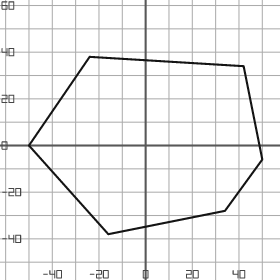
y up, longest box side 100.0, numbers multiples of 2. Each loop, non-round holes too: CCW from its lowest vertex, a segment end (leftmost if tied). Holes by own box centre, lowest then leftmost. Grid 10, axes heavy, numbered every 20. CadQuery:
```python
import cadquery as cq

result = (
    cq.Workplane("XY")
    .moveTo(-16.0, -38.0)
    .lineTo(34.0, -28.0)
    .lineTo(50.0, -6.0)
    .lineTo(42.0, 34.0)
    .lineTo(-24.0, 38.0)
    .lineTo(-50.0, 0.0)
    .close()
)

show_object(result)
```